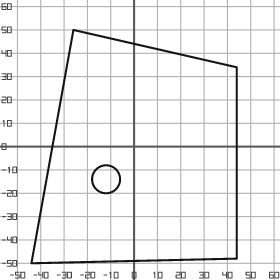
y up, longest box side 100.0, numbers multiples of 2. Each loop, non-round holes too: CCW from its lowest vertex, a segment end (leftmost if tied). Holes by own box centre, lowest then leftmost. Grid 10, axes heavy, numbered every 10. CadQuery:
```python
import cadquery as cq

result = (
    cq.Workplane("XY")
    .moveTo(-44.0, -50.0)
    .lineTo(44.0, -48.0)
    .lineTo(44.0, 34.0)
    .lineTo(-26.0, 50.0)
    .close()
    .moveTo(-12.0, -14.0)
    .circle(6.0)
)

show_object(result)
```